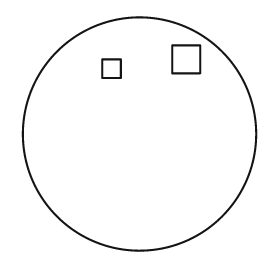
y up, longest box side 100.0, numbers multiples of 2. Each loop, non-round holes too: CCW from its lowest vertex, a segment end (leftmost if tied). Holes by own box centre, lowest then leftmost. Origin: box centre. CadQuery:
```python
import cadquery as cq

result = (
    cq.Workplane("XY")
    .moveTo(0.0, 0.0)
    .circle(50.0)
    .moveTo(-16.0, 24.0)
    .lineTo(-8.0, 24.0)
    .lineTo(-8.0, 32.0)
    .lineTo(-16.0, 32.0)
    .close()
    .moveTo(14.0, 26.0)
    .lineTo(26.0, 26.0)
    .lineTo(26.0, 38.0)
    .lineTo(14.0, 38.0)
    .close()
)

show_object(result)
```